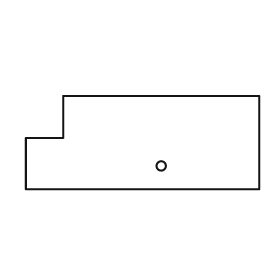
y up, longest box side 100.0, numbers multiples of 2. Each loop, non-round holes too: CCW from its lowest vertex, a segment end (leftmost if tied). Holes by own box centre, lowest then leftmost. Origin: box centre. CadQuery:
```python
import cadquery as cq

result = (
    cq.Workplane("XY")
    .moveTo(-50.0, -20.0)
    .lineTo(50.0, -20.0)
    .lineTo(50.0, 20.0)
    .lineTo(-34.0, 20.0)
    .lineTo(-34.0, 2.0)
    .lineTo(-50.0, 2.0)
    .close()
    .moveTo(8.0, -10.0)
    .circle(2.0)
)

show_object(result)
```